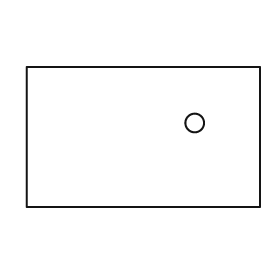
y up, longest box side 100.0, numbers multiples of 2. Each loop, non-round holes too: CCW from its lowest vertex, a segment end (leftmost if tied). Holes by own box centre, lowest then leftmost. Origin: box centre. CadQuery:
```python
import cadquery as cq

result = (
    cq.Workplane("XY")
    .moveTo(-50.0, -30.0)
    .lineTo(50.0, -30.0)
    .lineTo(50.0, 30.0)
    .lineTo(-50.0, 30.0)
    .close()
    .moveTo(22.0, 6.0)
    .circle(4.0)
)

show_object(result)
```